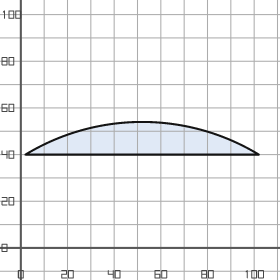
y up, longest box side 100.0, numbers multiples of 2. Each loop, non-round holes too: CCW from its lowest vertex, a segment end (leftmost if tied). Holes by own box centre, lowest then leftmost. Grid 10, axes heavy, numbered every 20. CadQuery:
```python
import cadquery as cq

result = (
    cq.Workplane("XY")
    .moveTo(2.0, 40.0)
    .lineTo(102.0, 40.0)
    .threePointArc((52.0, 54.0), (2.0, 40.0))
    .close()
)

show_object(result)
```